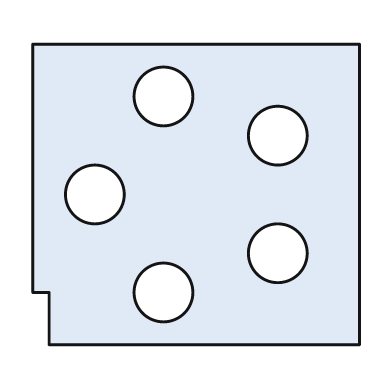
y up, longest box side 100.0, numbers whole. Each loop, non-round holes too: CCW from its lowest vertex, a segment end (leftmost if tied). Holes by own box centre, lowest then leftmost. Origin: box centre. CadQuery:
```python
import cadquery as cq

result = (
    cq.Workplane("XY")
    .moveTo(-45.0, -46.0)
    .lineTo(50.0, -46.0)
    .lineTo(50.0, 46.0)
    .lineTo(-50.0, 46.0)
    .lineTo(-50.0, -30.0)
    .lineTo(-45.0, -30.0)
    .close()
    .moveTo(-10.0, -30.0)
    .circle(9.0)
    .moveTo(25.0, -18.0)
    .circle(9.0)
    .moveTo(-31.0, 0.0)
    .circle(9.0)
    .moveTo(25.0, 18.0)
    .circle(9.0)
    .moveTo(-10.0, 30.0)
    .circle(9.0)
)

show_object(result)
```